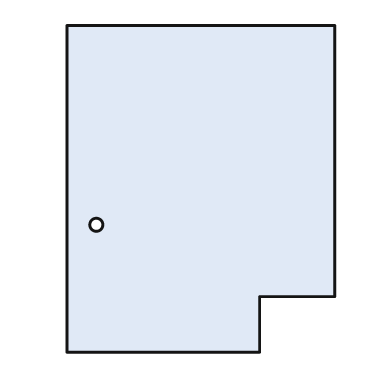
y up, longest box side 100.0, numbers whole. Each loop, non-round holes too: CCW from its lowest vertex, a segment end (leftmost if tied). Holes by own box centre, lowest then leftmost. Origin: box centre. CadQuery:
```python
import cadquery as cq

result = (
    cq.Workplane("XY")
    .moveTo(-41.0, -50.0)
    .lineTo(18.0, -50.0)
    .lineTo(18.0, -33.0)
    .lineTo(41.0, -33.0)
    .lineTo(41.0, 50.0)
    .lineTo(-41.0, 50.0)
    .close()
    .moveTo(-32.0, -11.0)
    .circle(2.0)
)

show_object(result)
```